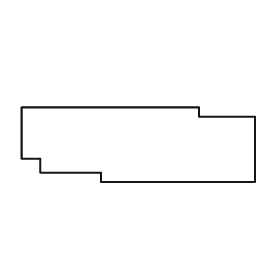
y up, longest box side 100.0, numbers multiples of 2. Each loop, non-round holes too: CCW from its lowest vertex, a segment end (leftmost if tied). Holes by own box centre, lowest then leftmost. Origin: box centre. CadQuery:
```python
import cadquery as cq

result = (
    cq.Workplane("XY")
    .moveTo(-16.0, -16.0)
    .lineTo(50.0, -16.0)
    .lineTo(50.0, 12.0)
    .lineTo(26.0, 12.0)
    .lineTo(26.0, 16.0)
    .lineTo(-50.0, 16.0)
    .lineTo(-50.0, -6.0)
    .lineTo(-42.0, -6.0)
    .lineTo(-42.0, -12.0)
    .lineTo(-16.0, -12.0)
    .close()
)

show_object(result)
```